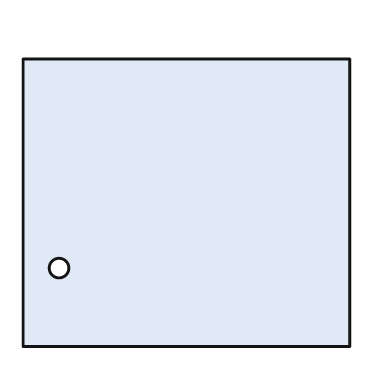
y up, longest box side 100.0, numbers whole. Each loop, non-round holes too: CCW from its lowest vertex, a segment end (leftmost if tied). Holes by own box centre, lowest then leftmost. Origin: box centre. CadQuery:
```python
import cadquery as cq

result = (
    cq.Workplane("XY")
    .moveTo(-50.0, -44.0)
    .lineTo(50.0, -44.0)
    .lineTo(50.0, 44.0)
    .lineTo(-50.0, 44.0)
    .close()
    .moveTo(-39.0, -20.0)
    .circle(3.0)
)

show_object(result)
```